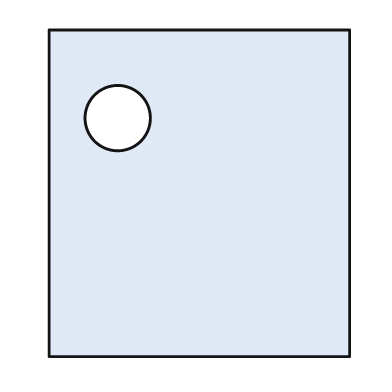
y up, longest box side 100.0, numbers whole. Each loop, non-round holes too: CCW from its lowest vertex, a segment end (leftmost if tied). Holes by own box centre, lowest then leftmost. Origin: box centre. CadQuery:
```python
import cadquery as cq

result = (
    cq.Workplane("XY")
    .moveTo(-46.0, -50.0)
    .lineTo(46.0, -50.0)
    .lineTo(46.0, 50.0)
    .lineTo(-46.0, 50.0)
    .close()
    .moveTo(-25.0, 23.0)
    .circle(10.0)
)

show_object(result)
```